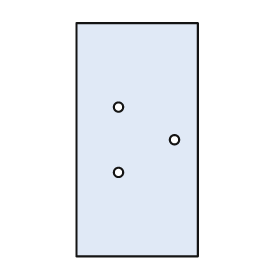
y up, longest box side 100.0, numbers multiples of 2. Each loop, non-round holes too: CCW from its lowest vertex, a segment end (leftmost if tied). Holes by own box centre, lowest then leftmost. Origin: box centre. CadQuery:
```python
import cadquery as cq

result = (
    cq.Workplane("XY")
    .moveTo(-26.0, -50.0)
    .lineTo(26.0, -50.0)
    .lineTo(26.0, 50.0)
    .lineTo(-26.0, 50.0)
    .close()
    .moveTo(-8.0, -14.0)
    .circle(2.0)
    .moveTo(16.0, 0.0)
    .circle(2.0)
    .moveTo(-8.0, 14.0)
    .circle(2.0)
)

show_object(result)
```